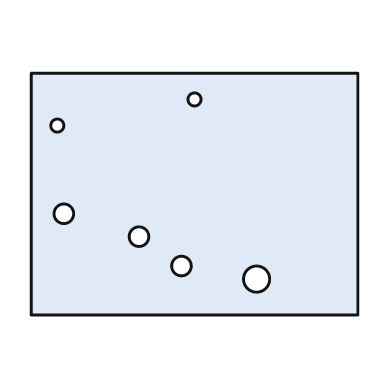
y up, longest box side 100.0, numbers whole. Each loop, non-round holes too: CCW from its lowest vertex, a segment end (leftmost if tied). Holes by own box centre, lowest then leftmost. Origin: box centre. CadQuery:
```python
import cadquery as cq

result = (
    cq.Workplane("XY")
    .moveTo(-50.0, -37.0)
    .lineTo(50.0, -37.0)
    .lineTo(50.0, 37.0)
    .lineTo(-50.0, 37.0)
    .close()
    .moveTo(19.0, -26.0)
    .circle(4.0)
    .moveTo(-4.0, -22.0)
    .circle(3.0)
    .moveTo(-17.0, -13.0)
    .circle(3.0)
    .moveTo(-40.0, -6.0)
    .circle(3.0)
    .moveTo(-42.0, 21.0)
    .circle(2.0)
    .moveTo(0.0, 29.0)
    .circle(2.0)
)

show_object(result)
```